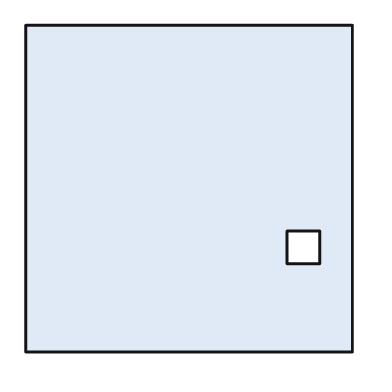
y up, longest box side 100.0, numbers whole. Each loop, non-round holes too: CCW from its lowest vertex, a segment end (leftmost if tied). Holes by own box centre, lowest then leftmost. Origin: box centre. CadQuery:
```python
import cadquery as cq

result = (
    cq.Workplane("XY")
    .moveTo(-50.0, -50.0)
    .lineTo(50.0, -50.0)
    .lineTo(50.0, 50.0)
    .lineTo(-50.0, 50.0)
    .close()
    .moveTo(30.0, -23.0)
    .lineTo(40.0, -23.0)
    .lineTo(40.0, -13.0)
    .lineTo(30.0, -13.0)
    .close()
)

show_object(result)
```